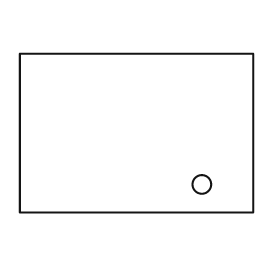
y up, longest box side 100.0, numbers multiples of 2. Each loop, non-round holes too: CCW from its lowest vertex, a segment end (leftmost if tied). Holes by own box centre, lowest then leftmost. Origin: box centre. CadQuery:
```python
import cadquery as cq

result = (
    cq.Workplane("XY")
    .moveTo(-50.0, -34.0)
    .lineTo(50.0, -34.0)
    .lineTo(50.0, 34.0)
    .lineTo(-50.0, 34.0)
    .close()
    .moveTo(28.0, -22.0)
    .circle(4.0)
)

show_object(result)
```